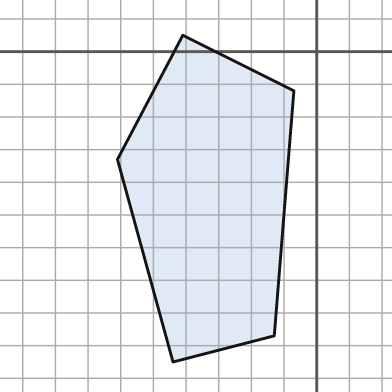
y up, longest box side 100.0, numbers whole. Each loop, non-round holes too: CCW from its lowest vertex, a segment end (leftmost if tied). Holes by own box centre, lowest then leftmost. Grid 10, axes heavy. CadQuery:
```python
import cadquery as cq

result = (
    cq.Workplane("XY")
    .moveTo(-44.0, -95.0)
    .lineTo(-13.0, -87.0)
    .lineTo(-7.0, -12.0)
    .lineTo(-41.0, 5.0)
    .lineTo(-61.0, -33.0)
    .close()
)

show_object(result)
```